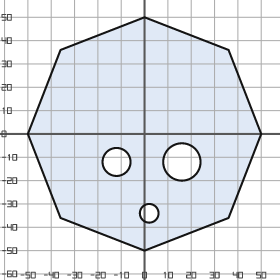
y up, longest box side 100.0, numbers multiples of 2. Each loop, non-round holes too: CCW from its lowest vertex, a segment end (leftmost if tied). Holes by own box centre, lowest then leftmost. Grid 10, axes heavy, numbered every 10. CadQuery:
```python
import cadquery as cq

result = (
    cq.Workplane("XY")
    .moveTo(0.0, -50.0)
    .lineTo(36.0, -36.0)
    .lineTo(50.0, 0.0)
    .lineTo(36.0, 36.0)
    .lineTo(0.0, 50.0)
    .lineTo(-36.0, 36.0)
    .lineTo(-50.0, 0.0)
    .lineTo(-36.0, -36.0)
    .close()
    .moveTo(2.0, -34.0)
    .circle(4.0)
    .moveTo(-12.0, -12.0)
    .circle(6.0)
    .moveTo(16.0, -12.0)
    .circle(8.0)
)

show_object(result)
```